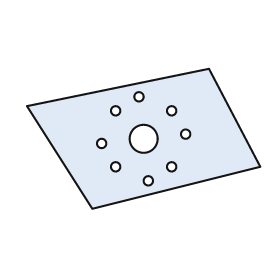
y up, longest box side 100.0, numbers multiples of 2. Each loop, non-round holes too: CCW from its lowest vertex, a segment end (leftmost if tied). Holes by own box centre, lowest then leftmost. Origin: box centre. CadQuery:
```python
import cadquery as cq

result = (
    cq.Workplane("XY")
    .moveTo(-22.0, -30.0)
    .lineTo(50.0, -12.0)
    .lineTo(28.0, 30.0)
    .lineTo(-50.0, 14.0)
    .close()
    .moveTo(2.0, -18.0)
    .circle(2.0)
    .moveTo(-12.0, -12.0)
    .circle(2.0)
    .moveTo(12.0, -12.0)
    .circle(2.0)
    .moveTo(-18.0, -2.0)
    .circle(2.0)
    .moveTo(0.0, 0.0)
    .circle(6.0)
    .moveTo(18.0, 2.0)
    .circle(2.0)
    .moveTo(-12.0, 12.0)
    .circle(2.0)
    .moveTo(12.0, 12.0)
    .circle(2.0)
    .moveTo(-2.0, 18.0)
    .circle(2.0)
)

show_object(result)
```